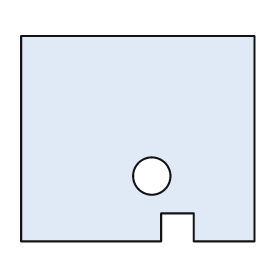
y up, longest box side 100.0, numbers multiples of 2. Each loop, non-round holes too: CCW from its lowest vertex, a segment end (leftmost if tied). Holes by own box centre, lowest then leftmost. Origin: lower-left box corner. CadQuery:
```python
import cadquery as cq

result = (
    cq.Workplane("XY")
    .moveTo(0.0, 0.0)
    .lineTo(60.0, 0.0)
    .lineTo(60.0, 12.0)
    .lineTo(74.0, 12.0)
    .lineTo(74.0, 0.0)
    .lineTo(100.0, 0.0)
    .lineTo(100.0, 88.0)
    .lineTo(0.0, 88.0)
    .close()
    .moveTo(56.0, 28.0)
    .circle(8.0)
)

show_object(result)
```